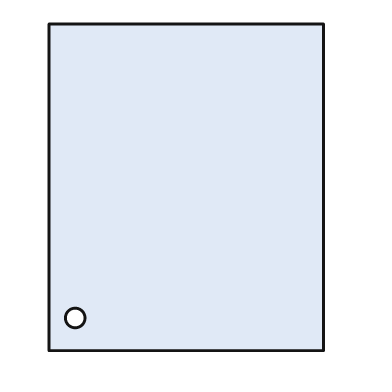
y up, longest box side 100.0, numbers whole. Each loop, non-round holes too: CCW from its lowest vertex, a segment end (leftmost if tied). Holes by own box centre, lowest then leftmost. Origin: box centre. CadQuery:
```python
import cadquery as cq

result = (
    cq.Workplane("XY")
    .moveTo(-42.0, -50.0)
    .lineTo(42.0, -50.0)
    .lineTo(42.0, 50.0)
    .lineTo(-42.0, 50.0)
    .close()
    .moveTo(-34.0, -40.0)
    .circle(3.0)
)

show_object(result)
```